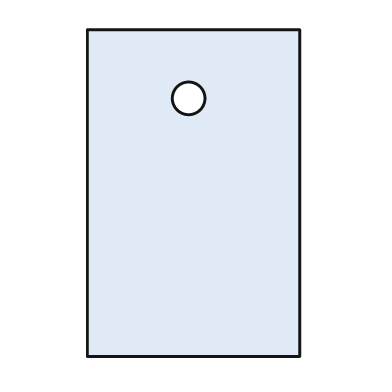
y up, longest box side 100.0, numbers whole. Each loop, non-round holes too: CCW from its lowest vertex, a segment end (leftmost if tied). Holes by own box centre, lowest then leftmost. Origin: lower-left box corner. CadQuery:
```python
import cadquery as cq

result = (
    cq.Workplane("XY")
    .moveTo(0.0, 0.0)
    .lineTo(65.0, 0.0)
    .lineTo(65.0, 100.0)
    .lineTo(0.0, 100.0)
    .close()
    .moveTo(31.0, 79.0)
    .circle(5.0)
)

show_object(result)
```